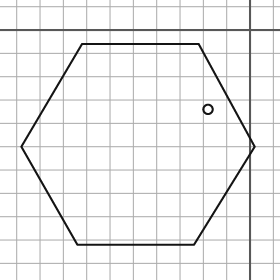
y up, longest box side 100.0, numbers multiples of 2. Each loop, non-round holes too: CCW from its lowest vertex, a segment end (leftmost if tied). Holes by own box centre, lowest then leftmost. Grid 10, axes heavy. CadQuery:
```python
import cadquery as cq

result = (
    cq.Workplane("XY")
    .moveTo(-74.0, -92.0)
    .lineTo(-24.0, -92.0)
    .lineTo(2.0, -50.0)
    .lineTo(-22.0, -6.0)
    .lineTo(-72.0, -6.0)
    .lineTo(-98.0, -50.0)
    .close()
    .moveTo(-18.0, -34.0)
    .circle(2.0)
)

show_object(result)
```